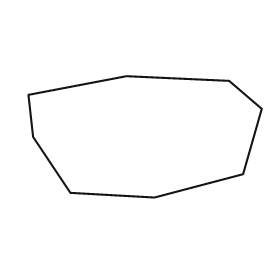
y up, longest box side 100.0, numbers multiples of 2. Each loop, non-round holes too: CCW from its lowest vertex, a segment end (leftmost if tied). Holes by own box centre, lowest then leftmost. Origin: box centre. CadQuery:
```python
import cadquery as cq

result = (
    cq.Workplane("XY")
    .moveTo(4.0, -26.0)
    .lineTo(42.0, -16.0)
    .lineTo(50.0, 12.0)
    .lineTo(36.0, 24.0)
    .lineTo(-8.0, 26.0)
    .lineTo(-50.0, 18.0)
    .lineTo(-48.0, 0.0)
    .lineTo(-32.0, -24.0)
    .close()
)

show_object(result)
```